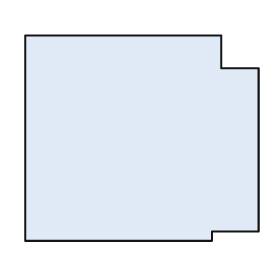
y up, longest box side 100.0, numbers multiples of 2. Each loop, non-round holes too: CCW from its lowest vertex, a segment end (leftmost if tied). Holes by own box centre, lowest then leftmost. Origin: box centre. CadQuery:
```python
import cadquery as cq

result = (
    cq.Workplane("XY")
    .moveTo(-50.0, -44.0)
    .lineTo(30.0, -44.0)
    .lineTo(30.0, -40.0)
    .lineTo(50.0, -40.0)
    .lineTo(50.0, 30.0)
    .lineTo(34.0, 30.0)
    .lineTo(34.0, 44.0)
    .lineTo(-50.0, 44.0)
    .close()
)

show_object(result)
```